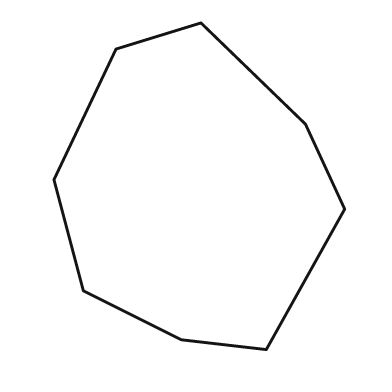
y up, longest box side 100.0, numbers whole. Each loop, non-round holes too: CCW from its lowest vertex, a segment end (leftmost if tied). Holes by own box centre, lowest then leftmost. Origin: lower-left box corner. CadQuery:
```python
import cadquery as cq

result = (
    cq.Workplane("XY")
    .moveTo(65.0, 0.0)
    .lineTo(89.0, 43.0)
    .lineTo(77.0, 69.0)
    .lineTo(45.0, 100.0)
    .lineTo(19.0, 92.0)
    .lineTo(0.0, 52.0)
    .lineTo(9.0, 18.0)
    .lineTo(39.0, 3.0)
    .close()
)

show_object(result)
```